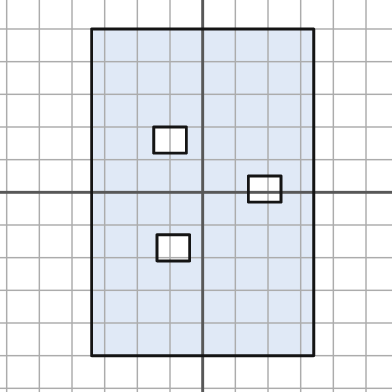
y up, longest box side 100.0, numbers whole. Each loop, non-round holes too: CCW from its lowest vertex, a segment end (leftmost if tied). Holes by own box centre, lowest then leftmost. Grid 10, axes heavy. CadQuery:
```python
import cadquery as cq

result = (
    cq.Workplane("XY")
    .moveTo(-34.0, -50.0)
    .lineTo(34.0, -50.0)
    .lineTo(34.0, 50.0)
    .lineTo(-34.0, 50.0)
    .close()
    .moveTo(-14.0, -21.0)
    .lineTo(-4.0, -21.0)
    .lineTo(-4.0, -13.0)
    .lineTo(-14.0, -13.0)
    .close()
    .moveTo(14.0, -3.0)
    .lineTo(24.0, -3.0)
    .lineTo(24.0, 5.0)
    .lineTo(14.0, 5.0)
    .close()
    .moveTo(-15.0, 12.0)
    .lineTo(-5.0, 12.0)
    .lineTo(-5.0, 20.0)
    .lineTo(-15.0, 20.0)
    .close()
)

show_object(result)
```